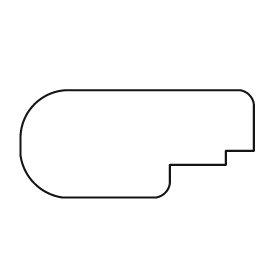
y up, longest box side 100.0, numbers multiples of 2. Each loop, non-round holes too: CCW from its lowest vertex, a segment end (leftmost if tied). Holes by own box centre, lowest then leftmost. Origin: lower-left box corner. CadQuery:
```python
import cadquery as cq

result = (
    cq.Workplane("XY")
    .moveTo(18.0, 0.0)
    .lineTo(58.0, 0.0)
    .threePointArc((62.0, 2.0), (64.0, 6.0))
    .lineTo(64.0, 14.0)
    .lineTo(88.0, 14.0)
    .lineTo(88.0, 20.0)
    .lineTo(100.0, 20.0)
    .lineTo(100.0, 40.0)
    .threePointArc((98.0, 44.0), (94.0, 46.0))
    .lineTo(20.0, 46.0)
    .threePointArc((6.0, 40.0), (0.0, 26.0))
    .lineTo(0.0, 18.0)
    .threePointArc((6.0, 6.0), (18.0, 0.0))
    .close()
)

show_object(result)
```